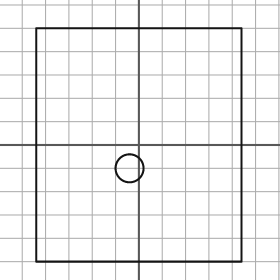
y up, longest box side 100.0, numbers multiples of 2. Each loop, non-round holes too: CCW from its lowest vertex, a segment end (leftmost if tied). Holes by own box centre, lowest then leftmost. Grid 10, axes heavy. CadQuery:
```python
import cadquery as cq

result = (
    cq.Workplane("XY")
    .moveTo(-44.0, -50.0)
    .lineTo(44.0, -50.0)
    .lineTo(44.0, 50.0)
    .lineTo(-44.0, 50.0)
    .close()
    .moveTo(-4.0, -10.0)
    .circle(6.0)
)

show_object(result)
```